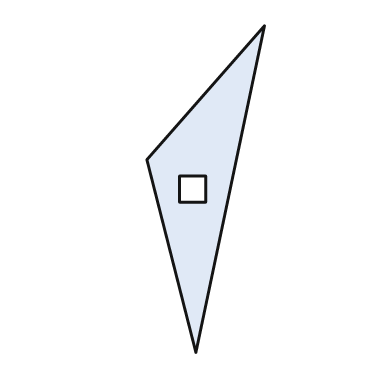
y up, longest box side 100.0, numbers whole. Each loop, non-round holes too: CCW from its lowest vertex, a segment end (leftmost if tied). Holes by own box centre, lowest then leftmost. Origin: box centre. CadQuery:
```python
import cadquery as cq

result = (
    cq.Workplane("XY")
    .moveTo(-3.0, -50.0)
    .lineTo(18.0, 50.0)
    .lineTo(-18.0, 9.0)
    .close()
    .moveTo(-8.0, -4.0)
    .lineTo(0.0, -4.0)
    .lineTo(0.0, 4.0)
    .lineTo(-8.0, 4.0)
    .close()
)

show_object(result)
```